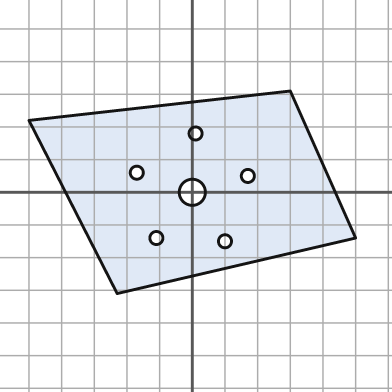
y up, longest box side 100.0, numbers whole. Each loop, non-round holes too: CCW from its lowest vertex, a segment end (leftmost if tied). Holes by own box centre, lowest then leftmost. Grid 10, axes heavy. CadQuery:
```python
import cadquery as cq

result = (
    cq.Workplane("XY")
    .moveTo(-23.0, -31.0)
    .lineTo(50.0, -14.0)
    .lineTo(30.0, 31.0)
    .lineTo(-50.0, 22.0)
    .close()
    .moveTo(10.0, -15.0)
    .circle(2.0)
    .moveTo(-11.0, -14.0)
    .circle(2.0)
    .moveTo(0.0, 0.0)
    .circle(4.0)
    .moveTo(17.0, 5.0)
    .circle(2.0)
    .moveTo(-17.0, 6.0)
    .circle(2.0)
    .moveTo(1.0, 18.0)
    .circle(2.0)
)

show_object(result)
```